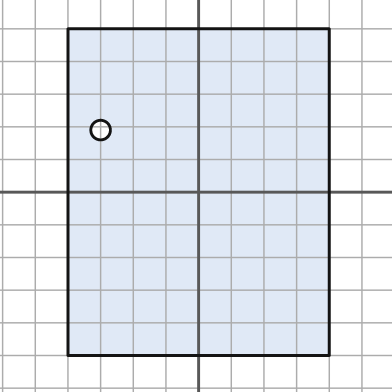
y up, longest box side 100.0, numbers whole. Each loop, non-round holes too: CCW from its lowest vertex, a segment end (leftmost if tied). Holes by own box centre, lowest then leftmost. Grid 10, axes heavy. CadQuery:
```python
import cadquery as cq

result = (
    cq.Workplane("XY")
    .moveTo(-40.0, -50.0)
    .lineTo(40.0, -50.0)
    .lineTo(40.0, 50.0)
    .lineTo(-40.0, 50.0)
    .close()
    .moveTo(-30.0, 19.0)
    .circle(3.0)
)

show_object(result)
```